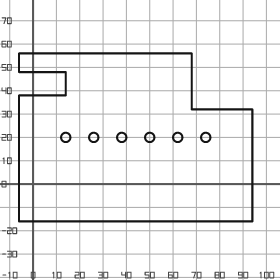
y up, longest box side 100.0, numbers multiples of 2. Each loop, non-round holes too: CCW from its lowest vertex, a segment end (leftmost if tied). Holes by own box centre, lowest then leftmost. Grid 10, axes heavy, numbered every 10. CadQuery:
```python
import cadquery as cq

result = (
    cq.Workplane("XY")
    .moveTo(-6.0, -16.0)
    .lineTo(94.0, -16.0)
    .lineTo(94.0, 32.0)
    .lineTo(68.0, 32.0)
    .lineTo(68.0, 56.0)
    .lineTo(-6.0, 56.0)
    .lineTo(-6.0, 48.0)
    .lineTo(14.0, 48.0)
    .lineTo(14.0, 38.0)
    .lineTo(-6.0, 38.0)
    .close()
    .moveTo(14.0, 20.0)
    .circle(2.0)
    .moveTo(26.0, 20.0)
    .circle(2.0)
    .moveTo(38.0, 20.0)
    .circle(2.0)
    .moveTo(50.0, 20.0)
    .circle(2.0)
    .moveTo(62.0, 20.0)
    .circle(2.0)
    .moveTo(74.0, 20.0)
    .circle(2.0)
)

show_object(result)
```